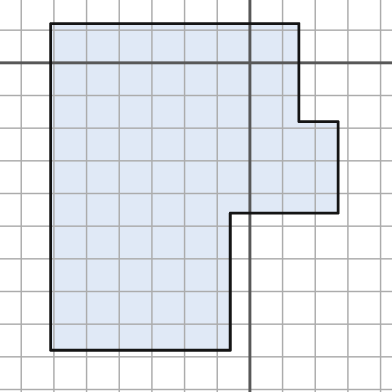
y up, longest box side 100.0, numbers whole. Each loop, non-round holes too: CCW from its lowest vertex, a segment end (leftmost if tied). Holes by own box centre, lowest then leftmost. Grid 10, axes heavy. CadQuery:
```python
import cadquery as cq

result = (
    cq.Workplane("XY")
    .moveTo(-61.0, -88.0)
    .lineTo(-6.0, -88.0)
    .lineTo(-6.0, -46.0)
    .lineTo(27.0, -46.0)
    .lineTo(27.0, -18.0)
    .lineTo(15.0, -18.0)
    .lineTo(15.0, 12.0)
    .lineTo(-61.0, 12.0)
    .close()
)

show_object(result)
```